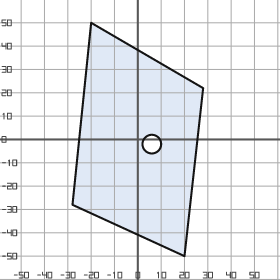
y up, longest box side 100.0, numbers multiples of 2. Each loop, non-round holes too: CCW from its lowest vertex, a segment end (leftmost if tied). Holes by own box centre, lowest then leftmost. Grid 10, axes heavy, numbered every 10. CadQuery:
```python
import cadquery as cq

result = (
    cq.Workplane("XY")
    .moveTo(20.0, -50.0)
    .lineTo(28.0, 22.0)
    .lineTo(-20.0, 50.0)
    .lineTo(-28.0, -28.0)
    .close()
    .moveTo(6.0, -2.0)
    .circle(4.0)
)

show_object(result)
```